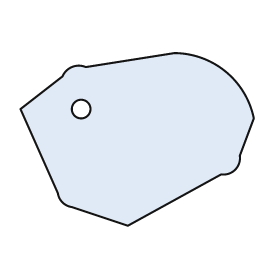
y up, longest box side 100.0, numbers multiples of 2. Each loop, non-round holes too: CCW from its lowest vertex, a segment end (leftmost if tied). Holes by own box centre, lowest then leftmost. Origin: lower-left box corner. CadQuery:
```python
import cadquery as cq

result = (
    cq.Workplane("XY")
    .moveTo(46.0, 0.0)
    .lineTo(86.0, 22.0)
    .threePointArc((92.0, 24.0), (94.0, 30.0))
    .lineTo(100.0, 46.0)
    .threePointArc((88.0, 66.0), (66.0, 74.0))
    .lineTo(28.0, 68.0)
    .threePointArc((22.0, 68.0), (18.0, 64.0))
    .lineTo(0.0, 50.0)
    .lineTo(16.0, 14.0)
    .threePointArc((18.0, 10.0), (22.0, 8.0))
    .close()
    .moveTo(26.0, 50.0)
    .circle(4.0)
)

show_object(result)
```